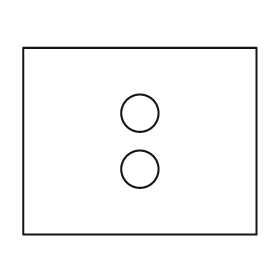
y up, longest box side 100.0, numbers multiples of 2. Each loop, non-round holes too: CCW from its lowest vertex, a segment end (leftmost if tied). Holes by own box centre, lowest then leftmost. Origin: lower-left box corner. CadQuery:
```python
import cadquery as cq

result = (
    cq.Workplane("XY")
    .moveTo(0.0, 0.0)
    .lineTo(100.0, 0.0)
    .lineTo(100.0, 80.0)
    .lineTo(0.0, 80.0)
    .close()
    .moveTo(50.0, 28.0)
    .circle(8.0)
    .moveTo(50.0, 52.0)
    .circle(8.0)
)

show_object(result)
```